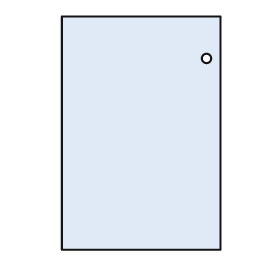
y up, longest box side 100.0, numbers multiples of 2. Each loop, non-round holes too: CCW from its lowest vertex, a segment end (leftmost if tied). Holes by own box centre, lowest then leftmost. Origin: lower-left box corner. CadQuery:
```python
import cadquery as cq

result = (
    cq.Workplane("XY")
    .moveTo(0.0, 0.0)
    .lineTo(68.0, 0.0)
    .lineTo(68.0, 100.0)
    .lineTo(0.0, 100.0)
    .close()
    .moveTo(62.0, 82.0)
    .circle(2.0)
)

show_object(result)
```